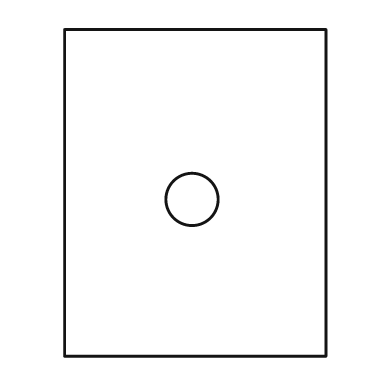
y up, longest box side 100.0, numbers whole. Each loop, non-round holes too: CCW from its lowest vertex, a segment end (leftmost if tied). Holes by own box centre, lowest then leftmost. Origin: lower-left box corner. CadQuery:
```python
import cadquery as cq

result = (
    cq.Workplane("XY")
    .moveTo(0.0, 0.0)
    .lineTo(80.0, 0.0)
    .lineTo(80.0, 100.0)
    .lineTo(0.0, 100.0)
    .close()
    .moveTo(39.0, 48.0)
    .circle(8.0)
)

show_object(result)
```